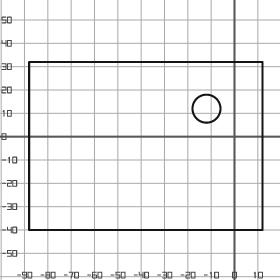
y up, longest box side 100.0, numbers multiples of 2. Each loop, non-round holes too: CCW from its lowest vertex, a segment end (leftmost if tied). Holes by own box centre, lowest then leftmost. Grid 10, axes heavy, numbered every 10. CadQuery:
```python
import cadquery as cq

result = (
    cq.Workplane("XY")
    .moveTo(-88.0, -40.0)
    .lineTo(12.0, -40.0)
    .lineTo(12.0, 32.0)
    .lineTo(-88.0, 32.0)
    .close()
    .moveTo(-12.0, 12.0)
    .circle(6.0)
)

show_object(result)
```